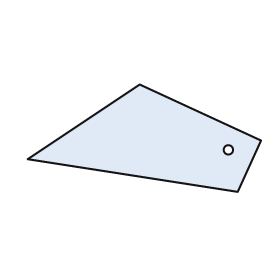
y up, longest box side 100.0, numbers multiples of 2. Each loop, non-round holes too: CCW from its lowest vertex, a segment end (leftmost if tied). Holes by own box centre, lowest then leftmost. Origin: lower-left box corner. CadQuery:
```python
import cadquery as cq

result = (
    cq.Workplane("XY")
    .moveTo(90.0, 0.0)
    .lineTo(100.0, 22.0)
    .lineTo(48.0, 46.0)
    .lineTo(0.0, 14.0)
    .close()
    .moveTo(86.0, 18.0)
    .circle(2.0)
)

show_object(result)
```